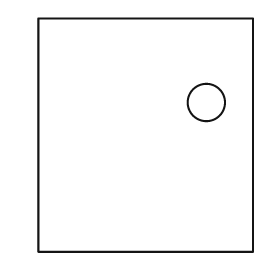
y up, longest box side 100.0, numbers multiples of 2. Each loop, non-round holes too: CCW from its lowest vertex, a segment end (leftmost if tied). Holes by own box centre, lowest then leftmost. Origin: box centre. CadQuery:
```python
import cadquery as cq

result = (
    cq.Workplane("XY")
    .moveTo(-46.0, -50.0)
    .lineTo(46.0, -50.0)
    .lineTo(46.0, 50.0)
    .lineTo(-46.0, 50.0)
    .close()
    .moveTo(26.0, 14.0)
    .circle(8.0)
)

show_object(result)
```